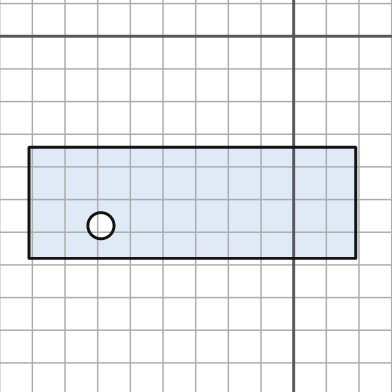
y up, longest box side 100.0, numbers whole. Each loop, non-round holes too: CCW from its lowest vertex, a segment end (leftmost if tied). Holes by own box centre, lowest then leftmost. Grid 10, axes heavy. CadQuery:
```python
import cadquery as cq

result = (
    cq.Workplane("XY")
    .moveTo(-81.0, -68.0)
    .lineTo(19.0, -68.0)
    .lineTo(19.0, -34.0)
    .lineTo(-81.0, -34.0)
    .close()
    .moveTo(-59.0, -58.0)
    .circle(4.0)
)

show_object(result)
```